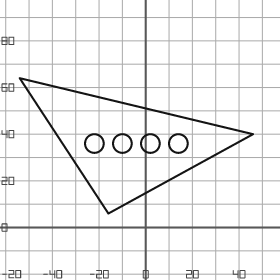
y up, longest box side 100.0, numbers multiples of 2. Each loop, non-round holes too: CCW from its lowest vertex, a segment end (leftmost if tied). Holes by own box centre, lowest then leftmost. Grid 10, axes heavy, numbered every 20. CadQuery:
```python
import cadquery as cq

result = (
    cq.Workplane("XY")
    .moveTo(-16.0, 6.0)
    .lineTo(46.0, 40.0)
    .lineTo(-54.0, 64.0)
    .close()
    .moveTo(-22.0, 36.0)
    .circle(4.0)
    .moveTo(-10.0, 36.0)
    .circle(4.0)
    .moveTo(2.0, 36.0)
    .circle(4.0)
    .moveTo(14.0, 36.0)
    .circle(4.0)
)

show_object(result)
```